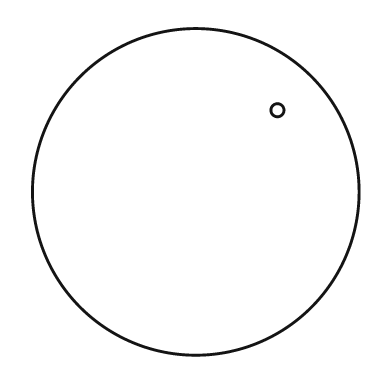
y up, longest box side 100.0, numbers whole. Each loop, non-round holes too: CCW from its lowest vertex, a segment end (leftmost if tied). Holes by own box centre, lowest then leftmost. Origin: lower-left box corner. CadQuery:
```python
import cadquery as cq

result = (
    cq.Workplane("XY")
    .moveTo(50.0, 50.0)
    .circle(50.0)
    .moveTo(75.0, 75.0)
    .circle(2.0)
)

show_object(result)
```